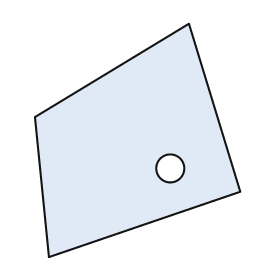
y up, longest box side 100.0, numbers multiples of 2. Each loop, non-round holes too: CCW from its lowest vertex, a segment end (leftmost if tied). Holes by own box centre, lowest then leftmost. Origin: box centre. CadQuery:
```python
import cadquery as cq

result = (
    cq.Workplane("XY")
    .moveTo(-38.0, -50.0)
    .lineTo(44.0, -22.0)
    .lineTo(22.0, 50.0)
    .lineTo(-44.0, 10.0)
    .close()
    .moveTo(14.0, -12.0)
    .circle(6.0)
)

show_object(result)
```